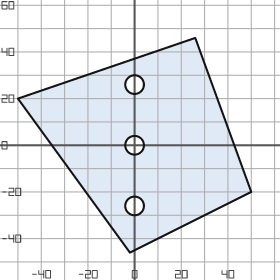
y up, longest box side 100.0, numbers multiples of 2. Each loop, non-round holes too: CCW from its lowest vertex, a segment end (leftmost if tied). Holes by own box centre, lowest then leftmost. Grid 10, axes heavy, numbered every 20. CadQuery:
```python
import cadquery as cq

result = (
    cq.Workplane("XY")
    .moveTo(-2.0, -46.0)
    .lineTo(50.0, -20.0)
    .lineTo(26.0, 46.0)
    .lineTo(-50.0, 20.0)
    .close()
    .moveTo(0.0, -26.0)
    .circle(4.0)
    .moveTo(0.0, 0.0)
    .circle(4.0)
    .moveTo(0.0, 26.0)
    .circle(4.0)
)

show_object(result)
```